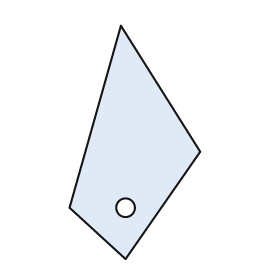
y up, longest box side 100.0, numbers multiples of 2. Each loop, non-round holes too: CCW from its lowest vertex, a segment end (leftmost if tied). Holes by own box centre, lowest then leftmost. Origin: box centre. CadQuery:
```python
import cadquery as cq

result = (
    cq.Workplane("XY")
    .moveTo(-4.0, -50.0)
    .lineTo(28.0, -4.0)
    .lineTo(-6.0, 50.0)
    .lineTo(-28.0, -28.0)
    .close()
    .moveTo(-4.0, -28.0)
    .circle(4.0)
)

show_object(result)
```